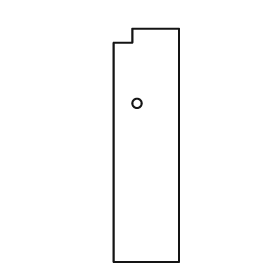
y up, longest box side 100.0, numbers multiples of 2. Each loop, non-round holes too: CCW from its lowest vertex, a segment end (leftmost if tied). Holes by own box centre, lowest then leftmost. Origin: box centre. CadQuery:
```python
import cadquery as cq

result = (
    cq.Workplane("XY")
    .moveTo(-14.0, -50.0)
    .lineTo(14.0, -50.0)
    .lineTo(14.0, 50.0)
    .lineTo(-6.0, 50.0)
    .lineTo(-6.0, 44.0)
    .lineTo(-14.0, 44.0)
    .close()
    .moveTo(-4.0, 18.0)
    .circle(2.0)
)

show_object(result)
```